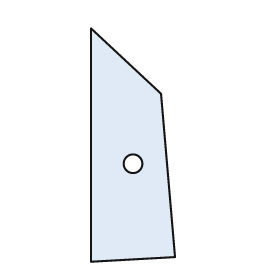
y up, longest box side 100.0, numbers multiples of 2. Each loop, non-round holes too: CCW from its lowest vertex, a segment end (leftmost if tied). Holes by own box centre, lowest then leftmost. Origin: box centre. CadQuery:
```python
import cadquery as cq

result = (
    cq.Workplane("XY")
    .moveTo(-18.0, -50.0)
    .lineTo(18.0, -48.0)
    .lineTo(12.0, 22.0)
    .lineTo(-18.0, 50.0)
    .close()
    .moveTo(0.0, -8.0)
    .circle(4.0)
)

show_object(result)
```